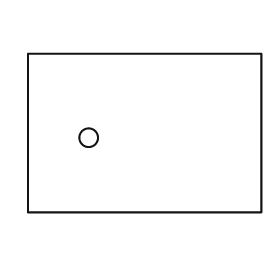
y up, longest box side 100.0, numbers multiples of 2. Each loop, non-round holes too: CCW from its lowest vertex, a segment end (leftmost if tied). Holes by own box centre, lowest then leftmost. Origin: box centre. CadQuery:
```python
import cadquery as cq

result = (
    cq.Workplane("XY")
    .moveTo(-50.0, -34.0)
    .lineTo(50.0, -34.0)
    .lineTo(50.0, 34.0)
    .lineTo(-50.0, 34.0)
    .close()
    .moveTo(-24.0, -2.0)
    .circle(4.0)
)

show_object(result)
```